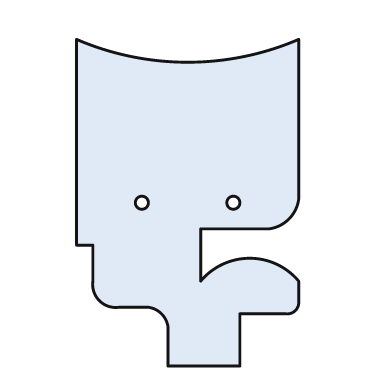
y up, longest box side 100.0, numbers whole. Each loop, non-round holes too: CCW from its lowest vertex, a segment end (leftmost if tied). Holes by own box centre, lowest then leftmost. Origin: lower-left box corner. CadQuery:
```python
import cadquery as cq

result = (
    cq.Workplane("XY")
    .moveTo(28.0, 0.0)
    .lineTo(50.0, 0.0)
    .lineTo(50.0, 16.0)
    .lineTo(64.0, 16.0)
    .threePointArc((67.0, 17.0), (68.0, 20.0))
    .lineTo(68.0, 26.0)
    .threePointArc((53.0, 33.0), (38.0, 26.0))
    .lineTo(38.0, 42.0)
    .lineTo(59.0, 42.0)
    .threePointArc((65.0, 45.0), (68.0, 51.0))
    .lineTo(68.0, 100.0)
    .threePointArc((34.0, 93.0), (0.0, 100.0))
    .lineTo(0.0, 37.0)
    .lineTo(5.0, 37.0)
    .lineTo(5.0, 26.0)
    .threePointArc((7.0, 20.0), (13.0, 18.0))
    .lineTo(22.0, 18.0)
    .threePointArc((26.0, 16.0), (28.0, 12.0))
    .close()
    .moveTo(20.0, 50.0)
    .circle(2.0)
    .moveTo(48.0, 50.0)
    .circle(2.0)
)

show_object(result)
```